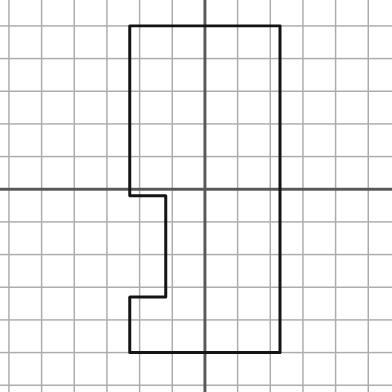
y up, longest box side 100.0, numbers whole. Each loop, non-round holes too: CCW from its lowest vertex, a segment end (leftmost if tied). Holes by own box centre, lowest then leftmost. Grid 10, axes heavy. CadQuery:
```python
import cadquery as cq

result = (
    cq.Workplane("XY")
    .moveTo(-23.0, -50.0)
    .lineTo(23.0, -50.0)
    .lineTo(23.0, 50.0)
    .lineTo(-23.0, 50.0)
    .lineTo(-23.0, -2.0)
    .lineTo(-12.0, -2.0)
    .lineTo(-12.0, -33.0)
    .lineTo(-23.0, -33.0)
    .close()
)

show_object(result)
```